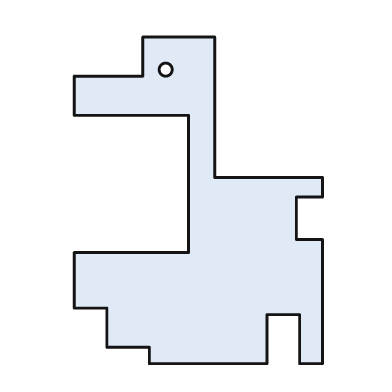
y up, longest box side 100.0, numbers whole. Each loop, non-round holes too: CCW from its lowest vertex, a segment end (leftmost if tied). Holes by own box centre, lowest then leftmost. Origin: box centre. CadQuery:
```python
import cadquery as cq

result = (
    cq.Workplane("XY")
    .moveTo(-15.0, -50.0)
    .lineTo(21.0, -50.0)
    .lineTo(21.0, -35.0)
    .lineTo(31.0, -35.0)
    .lineTo(31.0, -50.0)
    .lineTo(38.0, -50.0)
    .lineTo(38.0, -12.0)
    .lineTo(30.0, -12.0)
    .lineTo(30.0, 1.0)
    .lineTo(38.0, 1.0)
    .lineTo(38.0, 7.0)
    .lineTo(5.0, 7.0)
    .lineTo(5.0, 50.0)
    .lineTo(-17.0, 50.0)
    .lineTo(-17.0, 38.0)
    .lineTo(-38.0, 38.0)
    .lineTo(-38.0, 26.0)
    .lineTo(-3.0, 26.0)
    .lineTo(-3.0, -16.0)
    .lineTo(-38.0, -16.0)
    .lineTo(-38.0, -33.0)
    .lineTo(-28.0, -33.0)
    .lineTo(-28.0, -45.0)
    .lineTo(-15.0, -45.0)
    .close()
    .moveTo(-10.0, 40.0)
    .circle(2.0)
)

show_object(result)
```